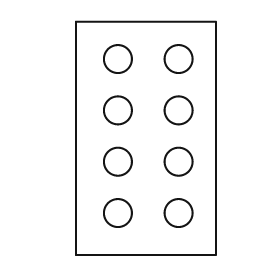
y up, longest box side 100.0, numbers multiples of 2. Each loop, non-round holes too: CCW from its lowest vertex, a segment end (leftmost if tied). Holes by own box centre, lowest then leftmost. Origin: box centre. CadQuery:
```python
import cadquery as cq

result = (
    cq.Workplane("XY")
    .moveTo(-30.0, -50.0)
    .lineTo(30.0, -50.0)
    .lineTo(30.0, 50.0)
    .lineTo(-30.0, 50.0)
    .close()
    .moveTo(-12.0, -32.0)
    .circle(6.0)
    .moveTo(14.0, -32.0)
    .circle(6.0)
    .moveTo(-12.0, -10.0)
    .circle(6.0)
    .moveTo(14.0, -10.0)
    .circle(6.0)
    .moveTo(-12.0, 12.0)
    .circle(6.0)
    .moveTo(14.0, 12.0)
    .circle(6.0)
    .moveTo(-12.0, 34.0)
    .circle(6.0)
    .moveTo(14.0, 34.0)
    .circle(6.0)
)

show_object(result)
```